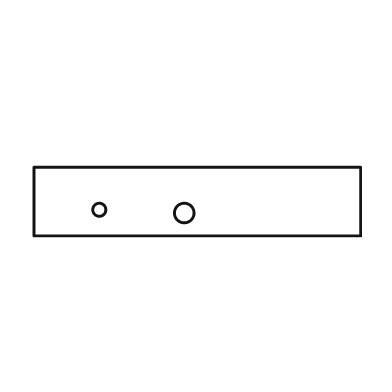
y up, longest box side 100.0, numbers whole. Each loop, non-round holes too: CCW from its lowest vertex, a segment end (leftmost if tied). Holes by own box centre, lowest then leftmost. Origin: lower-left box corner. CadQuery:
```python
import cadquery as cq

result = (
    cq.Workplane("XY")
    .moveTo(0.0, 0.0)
    .lineTo(100.0, 0.0)
    .lineTo(100.0, 21.0)
    .lineTo(0.0, 21.0)
    .close()
    .moveTo(46.0, 7.0)
    .circle(3.0)
    .moveTo(20.0, 8.0)
    .circle(2.0)
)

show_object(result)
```